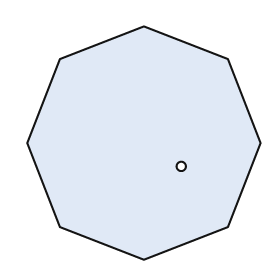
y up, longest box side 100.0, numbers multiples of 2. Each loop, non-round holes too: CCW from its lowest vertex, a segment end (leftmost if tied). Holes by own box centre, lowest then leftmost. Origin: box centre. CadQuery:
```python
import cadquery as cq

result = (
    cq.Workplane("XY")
    .moveTo(0.0, -50.0)
    .lineTo(36.0, -36.0)
    .lineTo(50.0, 0.0)
    .lineTo(36.0, 36.0)
    .lineTo(0.0, 50.0)
    .lineTo(-36.0, 36.0)
    .lineTo(-50.0, 0.0)
    .lineTo(-36.0, -36.0)
    .close()
    .moveTo(16.0, -10.0)
    .circle(2.0)
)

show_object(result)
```